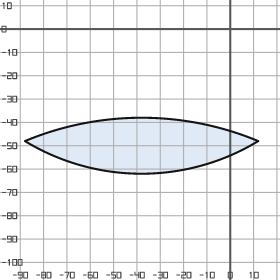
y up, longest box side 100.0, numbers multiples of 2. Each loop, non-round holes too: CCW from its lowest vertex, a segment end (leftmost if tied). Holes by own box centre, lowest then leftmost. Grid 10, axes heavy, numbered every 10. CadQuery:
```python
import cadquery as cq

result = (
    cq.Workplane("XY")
    .moveTo(-88.0, -48.0)
    .threePointArc((-38.0, -62.0), (12.0, -48.0))
    .threePointArc((-38.0, -38.0), (-88.0, -48.0))
    .close()
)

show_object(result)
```